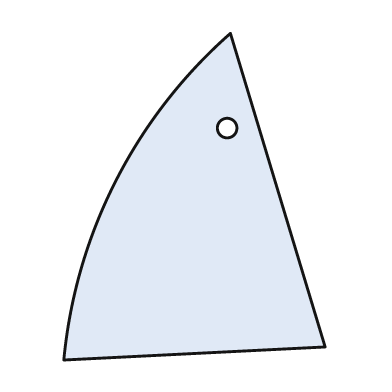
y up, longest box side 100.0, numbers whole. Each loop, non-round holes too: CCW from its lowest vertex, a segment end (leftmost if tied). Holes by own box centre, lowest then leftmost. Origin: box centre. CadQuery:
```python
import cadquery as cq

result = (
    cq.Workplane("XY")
    .moveTo(-40.0, -50.0)
    .lineTo(40.0, -46.0)
    .lineTo(11.0, 50.0)
    .threePointArc((-24.0, 5.0), (-40.0, -50.0))
    .close()
    .moveTo(10.0, 21.0)
    .circle(3.0)
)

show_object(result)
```